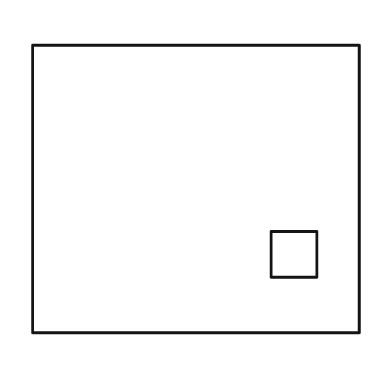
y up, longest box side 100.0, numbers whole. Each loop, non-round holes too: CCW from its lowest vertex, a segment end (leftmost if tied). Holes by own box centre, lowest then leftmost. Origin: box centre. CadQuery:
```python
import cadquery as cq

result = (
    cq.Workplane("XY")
    .moveTo(-50.0, -44.0)
    .lineTo(50.0, -44.0)
    .lineTo(50.0, 44.0)
    .lineTo(-50.0, 44.0)
    .close()
    .moveTo(23.0, -27.0)
    .lineTo(37.0, -27.0)
    .lineTo(37.0, -13.0)
    .lineTo(23.0, -13.0)
    .close()
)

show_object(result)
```